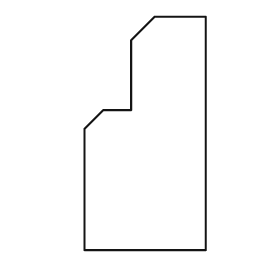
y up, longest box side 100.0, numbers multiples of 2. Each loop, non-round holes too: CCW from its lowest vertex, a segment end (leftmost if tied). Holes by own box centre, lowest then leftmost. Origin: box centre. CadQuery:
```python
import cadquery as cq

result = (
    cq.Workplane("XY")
    .moveTo(-26.0, -50.0)
    .lineTo(26.0, -50.0)
    .lineTo(26.0, 50.0)
    .lineTo(4.0, 50.0)
    .lineTo(-6.0, 40.0)
    .lineTo(-6.0, 10.0)
    .lineTo(-18.0, 10.0)
    .lineTo(-26.0, 2.0)
    .close()
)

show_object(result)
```